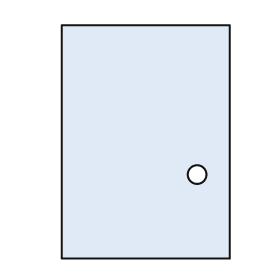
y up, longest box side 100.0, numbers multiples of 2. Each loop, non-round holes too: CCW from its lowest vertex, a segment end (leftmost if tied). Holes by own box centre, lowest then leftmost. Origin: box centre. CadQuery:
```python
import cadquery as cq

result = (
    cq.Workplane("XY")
    .moveTo(-36.0, -50.0)
    .lineTo(36.0, -50.0)
    .lineTo(36.0, 50.0)
    .lineTo(-36.0, 50.0)
    .close()
    .moveTo(22.0, -14.0)
    .circle(4.0)
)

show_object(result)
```